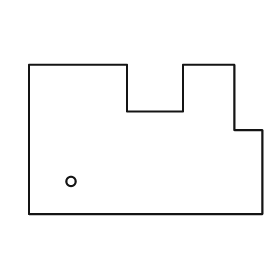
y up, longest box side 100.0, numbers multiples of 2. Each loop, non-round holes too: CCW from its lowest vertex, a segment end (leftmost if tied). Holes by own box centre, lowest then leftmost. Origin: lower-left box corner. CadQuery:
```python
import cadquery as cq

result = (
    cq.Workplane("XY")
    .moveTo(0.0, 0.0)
    .lineTo(100.0, 0.0)
    .lineTo(100.0, 36.0)
    .lineTo(88.0, 36.0)
    .lineTo(88.0, 64.0)
    .lineTo(66.0, 64.0)
    .lineTo(66.0, 44.0)
    .lineTo(42.0, 44.0)
    .lineTo(42.0, 64.0)
    .lineTo(0.0, 64.0)
    .close()
    .moveTo(18.0, 14.0)
    .circle(2.0)
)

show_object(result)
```